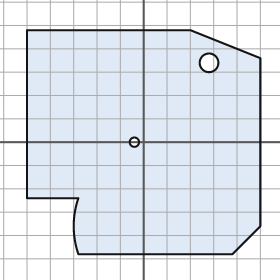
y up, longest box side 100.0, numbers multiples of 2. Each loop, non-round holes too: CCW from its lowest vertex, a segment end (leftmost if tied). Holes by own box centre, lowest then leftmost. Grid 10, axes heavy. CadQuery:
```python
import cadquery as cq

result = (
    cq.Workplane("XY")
    .moveTo(-28.0, -48.0)
    .lineTo(38.0, -48.0)
    .lineTo(50.0, -36.0)
    .lineTo(50.0, 36.0)
    .lineTo(20.0, 48.0)
    .lineTo(-50.0, 48.0)
    .lineTo(-50.0, -24.0)
    .lineTo(-28.0, -24.0)
    .threePointArc((-30.0, -36.0), (-28.0, -48.0))
    .close()
    .moveTo(-4.0, 0.0)
    .circle(2.0)
    .moveTo(28.0, 34.0)
    .circle(4.0)
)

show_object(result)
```